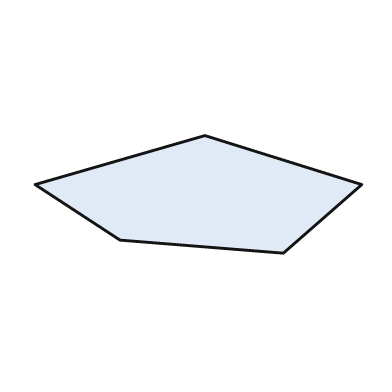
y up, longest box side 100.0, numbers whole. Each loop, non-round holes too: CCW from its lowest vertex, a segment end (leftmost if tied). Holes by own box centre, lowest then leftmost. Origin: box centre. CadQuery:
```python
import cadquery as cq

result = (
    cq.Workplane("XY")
    .moveTo(26.0, -18.0)
    .lineTo(50.0, 3.0)
    .lineTo(2.0, 18.0)
    .lineTo(-50.0, 3.0)
    .lineTo(-24.0, -14.0)
    .close()
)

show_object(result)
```